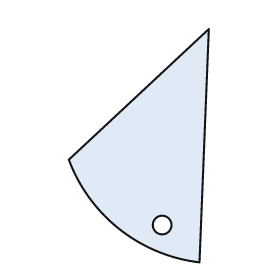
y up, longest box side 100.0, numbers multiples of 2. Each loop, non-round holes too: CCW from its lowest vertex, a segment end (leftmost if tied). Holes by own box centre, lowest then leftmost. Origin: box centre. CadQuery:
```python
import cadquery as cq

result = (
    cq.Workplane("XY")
    .moveTo(26.0, -50.0)
    .lineTo(30.0, 50.0)
    .lineTo(-30.0, -6.0)
    .threePointArc((-8.0, -36.0), (26.0, -50.0))
    .close()
    .moveTo(10.0, -34.0)
    .circle(4.0)
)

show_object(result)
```